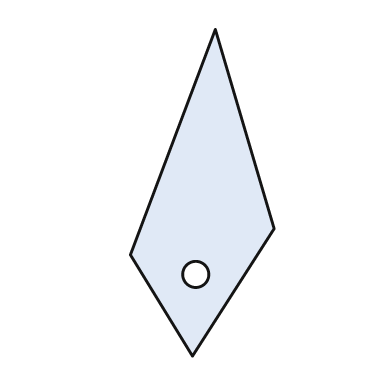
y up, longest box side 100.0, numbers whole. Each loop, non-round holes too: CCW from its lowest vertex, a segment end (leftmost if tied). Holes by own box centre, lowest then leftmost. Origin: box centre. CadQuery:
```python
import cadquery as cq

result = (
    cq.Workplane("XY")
    .moveTo(-3.0, -50.0)
    .lineTo(22.0, -11.0)
    .lineTo(4.0, 50.0)
    .lineTo(-22.0, -19.0)
    .close()
    .moveTo(-2.0, -25.0)
    .circle(4.0)
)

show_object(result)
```